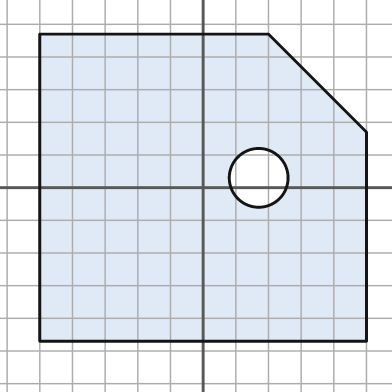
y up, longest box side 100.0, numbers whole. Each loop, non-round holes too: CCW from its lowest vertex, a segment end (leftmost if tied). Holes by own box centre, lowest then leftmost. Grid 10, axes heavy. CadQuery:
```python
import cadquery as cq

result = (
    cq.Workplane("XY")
    .moveTo(-50.0, -47.0)
    .lineTo(50.0, -47.0)
    .lineTo(50.0, 17.0)
    .lineTo(20.0, 47.0)
    .lineTo(-50.0, 47.0)
    .close()
    .moveTo(17.0, 3.0)
    .circle(9.0)
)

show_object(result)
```